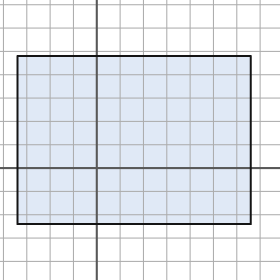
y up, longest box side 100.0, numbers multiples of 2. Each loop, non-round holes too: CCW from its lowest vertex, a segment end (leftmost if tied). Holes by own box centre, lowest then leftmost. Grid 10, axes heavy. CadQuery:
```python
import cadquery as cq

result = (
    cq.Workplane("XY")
    .moveTo(-34.0, -24.0)
    .lineTo(66.0, -24.0)
    .lineTo(66.0, 48.0)
    .lineTo(-34.0, 48.0)
    .close()
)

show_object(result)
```